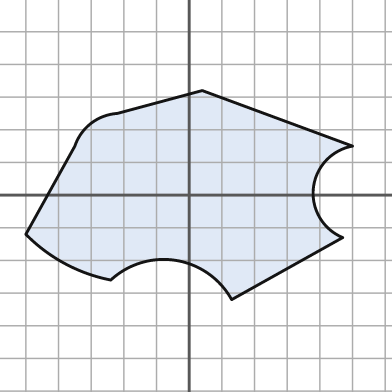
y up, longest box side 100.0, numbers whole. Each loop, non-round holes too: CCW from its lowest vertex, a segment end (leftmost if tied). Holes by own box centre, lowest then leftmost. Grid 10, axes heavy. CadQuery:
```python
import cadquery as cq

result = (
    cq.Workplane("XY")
    .moveTo(13.0, -32.0)
    .lineTo(47.0, -13.0)
    .threePointArc((38.0, 2.0), (50.0, 15.0))
    .lineTo(4.0, 32.0)
    .lineTo(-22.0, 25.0)
    .threePointArc((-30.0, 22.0), (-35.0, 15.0))
    .lineTo(-50.0, -12.0)
    .threePointArc((-38.0, -21.0), (-24.0, -26.0))
    .threePointArc((-4.0, -20.0), (13.0, -32.0))
    .close()
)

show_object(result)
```